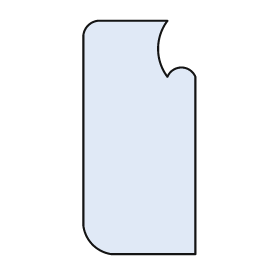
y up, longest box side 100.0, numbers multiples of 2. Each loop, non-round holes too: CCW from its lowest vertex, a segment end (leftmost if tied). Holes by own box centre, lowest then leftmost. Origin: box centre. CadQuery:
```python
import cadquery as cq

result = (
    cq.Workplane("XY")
    .moveTo(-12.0, -50.0)
    .lineTo(24.0, -50.0)
    .lineTo(24.0, 26.0)
    .threePointArc((18.0, 30.0), (12.0, 26.0))
    .threePointArc((8.0, 38.0), (12.0, 50.0))
    .lineTo(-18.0, 50.0)
    .threePointArc((-22.0, 48.0), (-24.0, 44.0))
    .lineTo(-24.0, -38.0)
    .threePointArc((-20.0, -46.0), (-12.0, -50.0))
    .close()
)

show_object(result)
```